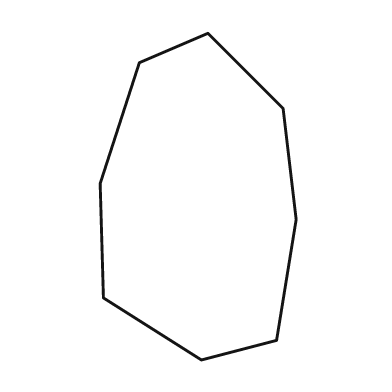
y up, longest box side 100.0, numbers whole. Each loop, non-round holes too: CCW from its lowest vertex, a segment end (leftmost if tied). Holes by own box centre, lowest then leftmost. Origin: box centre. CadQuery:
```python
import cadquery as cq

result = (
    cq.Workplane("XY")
    .moveTo(1.0, -50.0)
    .lineTo(24.0, -44.0)
    .lineTo(30.0, -7.0)
    .lineTo(26.0, 27.0)
    .lineTo(3.0, 50.0)
    .lineTo(-18.0, 41.0)
    .lineTo(-30.0, 4.0)
    .lineTo(-29.0, -31.0)
    .close()
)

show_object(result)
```